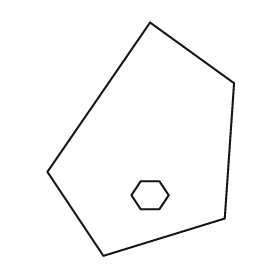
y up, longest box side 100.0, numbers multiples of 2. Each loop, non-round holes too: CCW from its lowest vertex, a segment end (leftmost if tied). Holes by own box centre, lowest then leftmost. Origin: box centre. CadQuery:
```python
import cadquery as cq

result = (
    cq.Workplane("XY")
    .moveTo(-16.0, -50.0)
    .lineTo(36.0, -34.0)
    .lineTo(40.0, 24.0)
    .lineTo(4.0, 50.0)
    .lineTo(-40.0, -14.0)
    .close()
    .moveTo(0.0, -30.0)
    .lineTo(8.0, -30.0)
    .lineTo(12.0, -24.0)
    .lineTo(8.0, -18.0)
    .lineTo(0.0, -18.0)
    .lineTo(-4.0, -24.0)
    .close()
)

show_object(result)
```